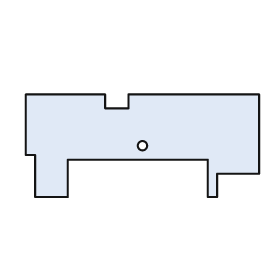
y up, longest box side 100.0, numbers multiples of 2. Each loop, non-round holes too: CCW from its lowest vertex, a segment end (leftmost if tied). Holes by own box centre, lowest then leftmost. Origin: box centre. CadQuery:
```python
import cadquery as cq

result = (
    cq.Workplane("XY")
    .moveTo(-46.0, -22.0)
    .lineTo(-32.0, -22.0)
    .lineTo(-32.0, -6.0)
    .lineTo(28.0, -6.0)
    .lineTo(28.0, -22.0)
    .lineTo(32.0, -22.0)
    .lineTo(32.0, -12.0)
    .lineTo(50.0, -12.0)
    .lineTo(50.0, 22.0)
    .lineTo(-6.0, 22.0)
    .lineTo(-6.0, 16.0)
    .lineTo(-16.0, 16.0)
    .lineTo(-16.0, 22.0)
    .lineTo(-50.0, 22.0)
    .lineTo(-50.0, -4.0)
    .lineTo(-46.0, -4.0)
    .close()
    .moveTo(0.0, 0.0)
    .circle(2.0)
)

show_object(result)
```